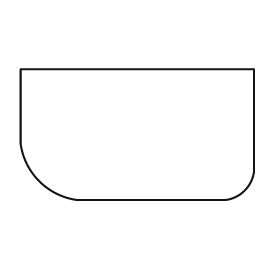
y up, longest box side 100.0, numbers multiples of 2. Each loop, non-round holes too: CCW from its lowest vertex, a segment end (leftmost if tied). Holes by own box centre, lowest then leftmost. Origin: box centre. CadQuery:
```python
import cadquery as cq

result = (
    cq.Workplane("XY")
    .moveTo(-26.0, -28.0)
    .lineTo(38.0, -28.0)
    .threePointArc((46.0, -24.0), (50.0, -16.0))
    .lineTo(50.0, 28.0)
    .lineTo(-50.0, 28.0)
    .lineTo(-50.0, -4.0)
    .threePointArc((-42.0, -20.0), (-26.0, -28.0))
    .close()
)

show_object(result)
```